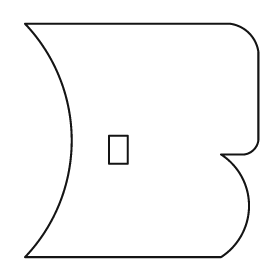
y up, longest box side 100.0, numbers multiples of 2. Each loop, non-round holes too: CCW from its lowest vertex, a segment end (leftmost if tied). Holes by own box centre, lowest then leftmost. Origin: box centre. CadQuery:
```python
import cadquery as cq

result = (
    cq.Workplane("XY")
    .moveTo(-50.0, -50.0)
    .lineTo(34.0, -50.0)
    .threePointArc((46.0, -28.0), (34.0, -6.0))
    .lineTo(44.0, -6.0)
    .threePointArc((48.0, -4.0), (50.0, 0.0))
    .lineTo(50.0, 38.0)
    .threePointArc((46.0, 46.0), (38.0, 50.0))
    .lineTo(-50.0, 50.0)
    .threePointArc((-30.0, 0.0), (-50.0, -50.0))
    .close()
    .moveTo(-14.0, -10.0)
    .lineTo(-6.0, -10.0)
    .lineTo(-6.0, 2.0)
    .lineTo(-14.0, 2.0)
    .close()
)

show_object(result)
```